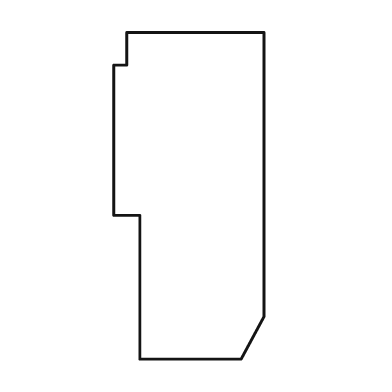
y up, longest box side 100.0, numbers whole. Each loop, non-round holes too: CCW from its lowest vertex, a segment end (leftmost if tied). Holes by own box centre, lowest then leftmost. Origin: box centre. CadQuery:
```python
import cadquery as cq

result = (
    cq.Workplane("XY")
    .moveTo(-15.0, -50.0)
    .lineTo(16.0, -50.0)
    .lineTo(23.0, -37.0)
    .lineTo(23.0, 50.0)
    .lineTo(-19.0, 50.0)
    .lineTo(-19.0, 40.0)
    .lineTo(-23.0, 40.0)
    .lineTo(-23.0, -6.0)
    .lineTo(-15.0, -6.0)
    .close()
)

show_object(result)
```